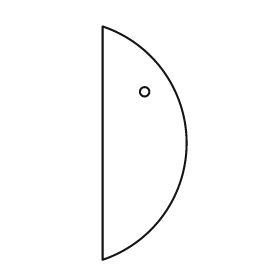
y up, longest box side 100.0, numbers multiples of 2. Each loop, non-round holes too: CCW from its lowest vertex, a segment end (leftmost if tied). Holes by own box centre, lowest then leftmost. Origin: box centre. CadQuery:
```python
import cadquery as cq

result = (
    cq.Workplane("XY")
    .moveTo(-18.0, -50.0)
    .threePointArc((18.0, 0.0), (-18.0, 50.0))
    .close()
    .moveTo(0.0, 22.0)
    .circle(2.0)
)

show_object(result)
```